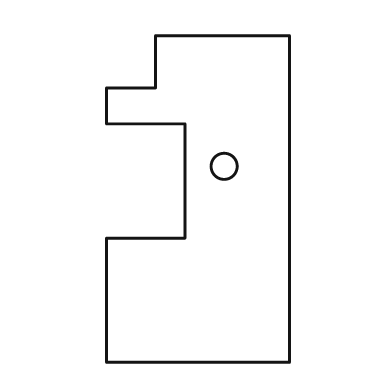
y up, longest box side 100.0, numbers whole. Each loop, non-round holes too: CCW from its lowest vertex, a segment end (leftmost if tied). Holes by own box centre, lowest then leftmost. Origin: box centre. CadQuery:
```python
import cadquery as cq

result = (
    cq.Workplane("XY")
    .moveTo(-28.0, -50.0)
    .lineTo(28.0, -50.0)
    .lineTo(28.0, 50.0)
    .lineTo(-13.0, 50.0)
    .lineTo(-13.0, 34.0)
    .lineTo(-28.0, 34.0)
    .lineTo(-28.0, 23.0)
    .lineTo(-4.0, 23.0)
    .lineTo(-4.0, -12.0)
    .lineTo(-28.0, -12.0)
    .close()
    .moveTo(8.0, 10.0)
    .circle(4.0)
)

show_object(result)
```